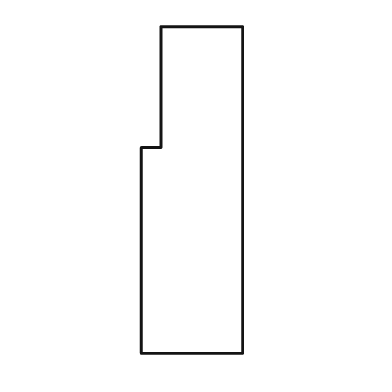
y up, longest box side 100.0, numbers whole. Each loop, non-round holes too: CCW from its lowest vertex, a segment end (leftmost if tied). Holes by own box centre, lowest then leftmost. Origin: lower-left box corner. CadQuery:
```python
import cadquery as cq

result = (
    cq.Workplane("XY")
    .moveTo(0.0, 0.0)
    .lineTo(31.0, 0.0)
    .lineTo(31.0, 100.0)
    .lineTo(6.0, 100.0)
    .lineTo(6.0, 63.0)
    .lineTo(0.0, 63.0)
    .close()
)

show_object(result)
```